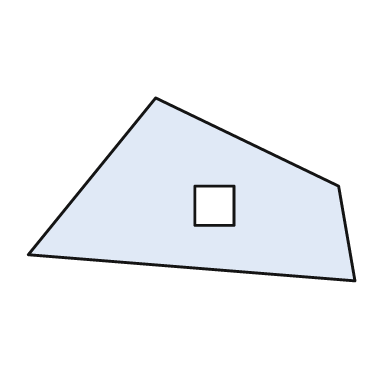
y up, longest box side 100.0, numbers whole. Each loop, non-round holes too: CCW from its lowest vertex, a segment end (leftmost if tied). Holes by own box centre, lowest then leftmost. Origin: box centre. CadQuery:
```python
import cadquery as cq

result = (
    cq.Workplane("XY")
    .moveTo(50.0, -28.0)
    .lineTo(45.0, 1.0)
    .lineTo(-11.0, 28.0)
    .lineTo(-50.0, -20.0)
    .close()
    .moveTo(1.0, -11.0)
    .lineTo(13.0, -11.0)
    .lineTo(13.0, 1.0)
    .lineTo(1.0, 1.0)
    .close()
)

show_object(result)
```